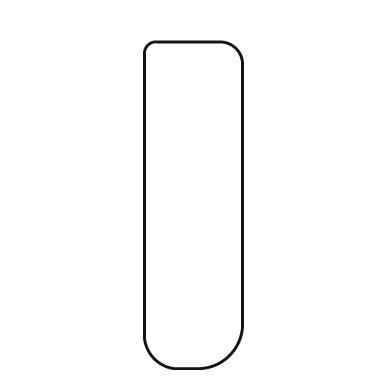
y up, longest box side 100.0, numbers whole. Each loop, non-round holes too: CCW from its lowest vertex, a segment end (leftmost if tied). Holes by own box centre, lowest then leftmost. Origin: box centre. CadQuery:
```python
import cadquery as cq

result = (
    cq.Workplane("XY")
    .moveTo(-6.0, -50.0)
    .lineTo(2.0, -50.0)
    .threePointArc((11.0, -46.0), (15.0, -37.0))
    .lineTo(15.0, 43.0)
    .threePointArc((13.0, 48.0), (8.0, 50.0))
    .lineTo(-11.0, 50.0)
    .threePointArc((-14.0, 49.0), (-15.0, 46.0))
    .lineTo(-15.0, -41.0)
    .threePointArc((-12.0, -47.0), (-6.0, -50.0))
    .close()
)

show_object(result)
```